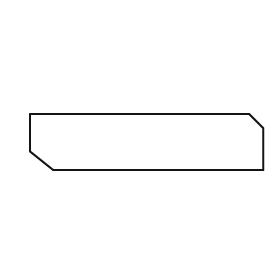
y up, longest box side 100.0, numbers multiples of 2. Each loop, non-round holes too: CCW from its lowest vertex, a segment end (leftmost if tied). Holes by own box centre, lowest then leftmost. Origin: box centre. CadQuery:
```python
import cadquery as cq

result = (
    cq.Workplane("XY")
    .moveTo(-40.0, -12.0)
    .lineTo(50.0, -12.0)
    .lineTo(50.0, 6.0)
    .lineTo(44.0, 12.0)
    .lineTo(-50.0, 12.0)
    .lineTo(-50.0, -4.0)
    .close()
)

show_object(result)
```